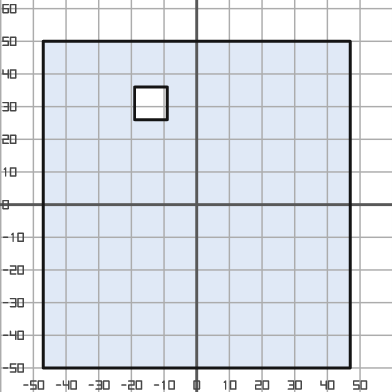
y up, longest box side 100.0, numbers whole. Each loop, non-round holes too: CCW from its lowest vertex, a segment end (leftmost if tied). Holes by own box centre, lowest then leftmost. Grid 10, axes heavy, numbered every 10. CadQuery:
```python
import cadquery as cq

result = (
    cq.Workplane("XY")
    .moveTo(-47.0, -50.0)
    .lineTo(47.0, -50.0)
    .lineTo(47.0, 50.0)
    .lineTo(-47.0, 50.0)
    .close()
    .moveTo(-19.0, 26.0)
    .lineTo(-9.0, 26.0)
    .lineTo(-9.0, 36.0)
    .lineTo(-19.0, 36.0)
    .close()
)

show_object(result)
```